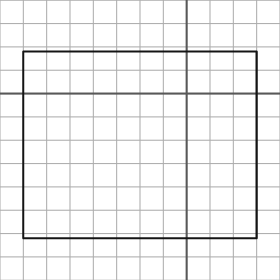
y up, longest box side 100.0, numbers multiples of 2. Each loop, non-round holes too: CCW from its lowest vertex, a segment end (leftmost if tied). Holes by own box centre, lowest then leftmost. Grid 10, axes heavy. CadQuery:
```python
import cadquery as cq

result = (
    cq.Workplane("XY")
    .moveTo(-70.0, -62.0)
    .lineTo(30.0, -62.0)
    .lineTo(30.0, 18.0)
    .lineTo(-70.0, 18.0)
    .close()
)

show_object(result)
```